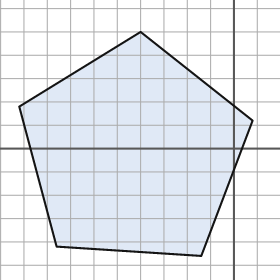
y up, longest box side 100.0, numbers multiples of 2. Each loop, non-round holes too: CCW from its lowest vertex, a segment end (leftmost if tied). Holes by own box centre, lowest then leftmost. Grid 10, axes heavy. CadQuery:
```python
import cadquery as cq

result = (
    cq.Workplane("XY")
    .moveTo(-14.0, -46.0)
    .lineTo(8.0, 12.0)
    .lineTo(-40.0, 50.0)
    .lineTo(-92.0, 18.0)
    .lineTo(-76.0, -42.0)
    .close()
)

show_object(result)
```